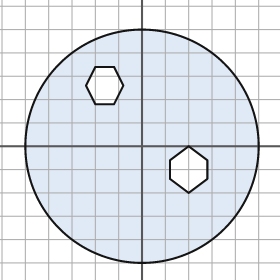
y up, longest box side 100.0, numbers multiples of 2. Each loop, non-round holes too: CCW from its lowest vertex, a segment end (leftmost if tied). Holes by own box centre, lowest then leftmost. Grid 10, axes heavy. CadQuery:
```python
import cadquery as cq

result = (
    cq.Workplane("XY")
    .moveTo(0.0, 0.0)
    .circle(50.0)
    .moveTo(20.0, -20.0)
    .lineTo(28.0, -14.0)
    .lineTo(28.0, -6.0)
    .lineTo(20.0, 0.0)
    .lineTo(12.0, -6.0)
    .lineTo(12.0, -14.0)
    .close()
    .moveTo(-20.0, 18.0)
    .lineTo(-12.0, 18.0)
    .lineTo(-8.0, 26.0)
    .lineTo(-12.0, 34.0)
    .lineTo(-20.0, 34.0)
    .lineTo(-24.0, 26.0)
    .close()
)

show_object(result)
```